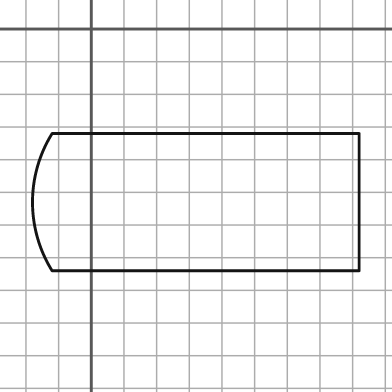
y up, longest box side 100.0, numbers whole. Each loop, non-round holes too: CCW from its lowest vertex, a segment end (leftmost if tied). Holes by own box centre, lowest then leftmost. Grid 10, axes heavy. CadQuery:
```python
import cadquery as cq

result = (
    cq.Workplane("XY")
    .moveTo(-12.0, -74.0)
    .lineTo(82.0, -74.0)
    .lineTo(82.0, -32.0)
    .lineTo(-12.0, -32.0)
    .threePointArc((-18.0, -53.0), (-12.0, -74.0))
    .close()
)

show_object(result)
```